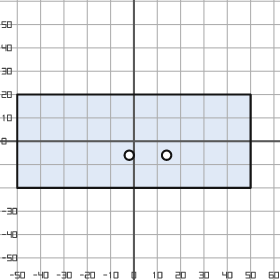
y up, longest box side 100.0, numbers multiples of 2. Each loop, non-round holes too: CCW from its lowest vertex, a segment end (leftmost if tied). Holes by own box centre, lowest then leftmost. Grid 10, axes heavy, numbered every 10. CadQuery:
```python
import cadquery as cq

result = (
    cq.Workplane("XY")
    .moveTo(-50.0, -20.0)
    .lineTo(50.0, -20.0)
    .lineTo(50.0, 20.0)
    .lineTo(-50.0, 20.0)
    .close()
    .moveTo(-2.0, -6.0)
    .circle(2.0)
    .moveTo(14.0, -6.0)
    .circle(2.0)
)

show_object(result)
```